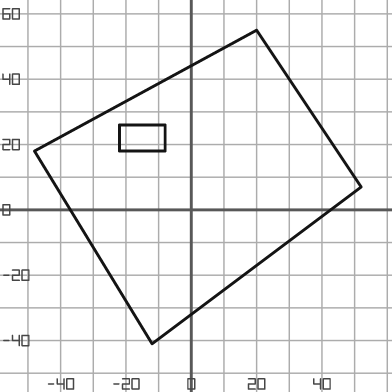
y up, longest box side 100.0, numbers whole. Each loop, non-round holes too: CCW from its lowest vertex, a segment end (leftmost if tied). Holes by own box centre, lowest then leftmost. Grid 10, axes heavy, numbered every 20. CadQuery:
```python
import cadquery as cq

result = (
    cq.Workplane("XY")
    .moveTo(-12.0, -41.0)
    .lineTo(52.0, 7.0)
    .lineTo(20.0, 55.0)
    .lineTo(-48.0, 18.0)
    .close()
    .moveTo(-22.0, 18.0)
    .lineTo(-8.0, 18.0)
    .lineTo(-8.0, 26.0)
    .lineTo(-22.0, 26.0)
    .close()
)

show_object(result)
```